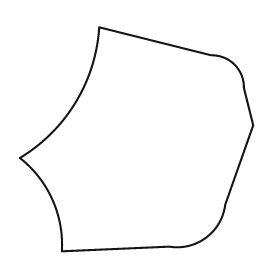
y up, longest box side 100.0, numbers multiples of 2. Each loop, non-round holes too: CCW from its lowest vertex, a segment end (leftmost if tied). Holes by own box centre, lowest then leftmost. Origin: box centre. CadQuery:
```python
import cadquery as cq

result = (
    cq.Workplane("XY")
    .moveTo(-32.0, -48.0)
    .lineTo(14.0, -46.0)
    .threePointArc((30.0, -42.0), (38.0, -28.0))
    .lineTo(50.0, 6.0)
    .lineTo(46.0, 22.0)
    .threePointArc((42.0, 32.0), (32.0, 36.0))
    .lineTo(-16.0, 48.0)
    .threePointArc((-26.0, 16.0), (-50.0, -8.0))
    .threePointArc((-36.0, -26.0), (-32.0, -48.0))
    .close()
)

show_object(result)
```